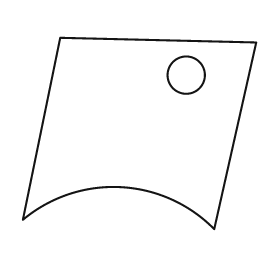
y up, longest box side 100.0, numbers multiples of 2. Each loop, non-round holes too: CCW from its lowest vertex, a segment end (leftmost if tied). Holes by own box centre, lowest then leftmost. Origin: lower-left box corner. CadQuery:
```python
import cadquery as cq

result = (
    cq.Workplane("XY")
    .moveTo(82.0, 0.0)
    .lineTo(100.0, 80.0)
    .lineTo(16.0, 82.0)
    .lineTo(0.0, 4.0)
    .threePointArc((42.0, 18.0), (82.0, 0.0))
    .close()
    .moveTo(70.0, 66.0)
    .circle(8.0)
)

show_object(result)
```